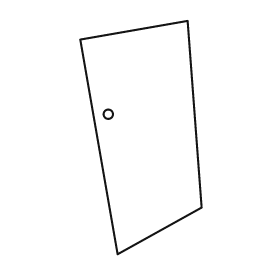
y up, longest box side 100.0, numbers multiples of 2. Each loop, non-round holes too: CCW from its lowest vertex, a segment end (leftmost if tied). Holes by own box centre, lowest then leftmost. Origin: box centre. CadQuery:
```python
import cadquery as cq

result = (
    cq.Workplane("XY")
    .moveTo(-10.0, -50.0)
    .lineTo(26.0, -30.0)
    .lineTo(20.0, 50.0)
    .lineTo(-26.0, 42.0)
    .close()
    .moveTo(-14.0, 10.0)
    .circle(2.0)
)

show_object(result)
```